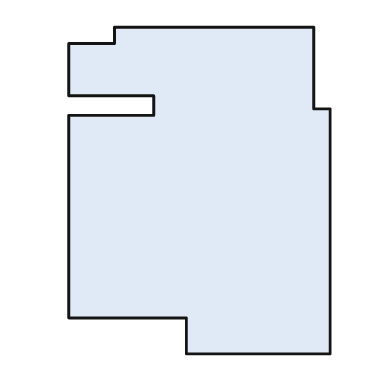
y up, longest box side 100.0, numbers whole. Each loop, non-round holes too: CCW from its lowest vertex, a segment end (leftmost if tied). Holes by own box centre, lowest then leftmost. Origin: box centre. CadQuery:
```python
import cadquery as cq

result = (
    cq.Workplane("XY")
    .moveTo(-4.0, -50.0)
    .lineTo(40.0, -50.0)
    .lineTo(40.0, 25.0)
    .lineTo(35.0, 25.0)
    .lineTo(35.0, 50.0)
    .lineTo(-26.0, 50.0)
    .lineTo(-26.0, 45.0)
    .lineTo(-40.0, 45.0)
    .lineTo(-40.0, 29.0)
    .lineTo(-14.0, 29.0)
    .lineTo(-14.0, 23.0)
    .lineTo(-40.0, 23.0)
    .lineTo(-40.0, -39.0)
    .lineTo(-4.0, -39.0)
    .close()
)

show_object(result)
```